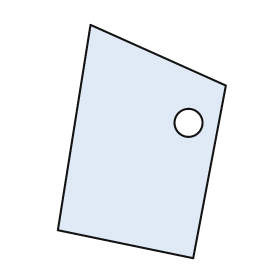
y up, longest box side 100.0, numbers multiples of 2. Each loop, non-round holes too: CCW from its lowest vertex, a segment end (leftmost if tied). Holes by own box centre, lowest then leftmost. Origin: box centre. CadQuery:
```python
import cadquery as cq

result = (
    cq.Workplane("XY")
    .moveTo(22.0, -50.0)
    .lineTo(36.0, 24.0)
    .lineTo(-22.0, 50.0)
    .lineTo(-36.0, -38.0)
    .close()
    .moveTo(20.0, 8.0)
    .circle(6.0)
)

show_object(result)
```